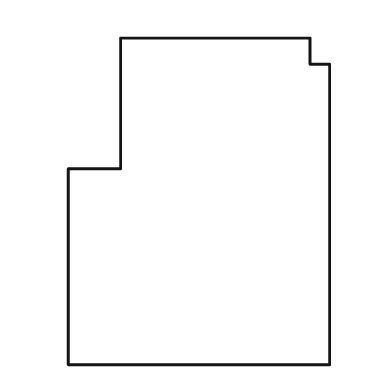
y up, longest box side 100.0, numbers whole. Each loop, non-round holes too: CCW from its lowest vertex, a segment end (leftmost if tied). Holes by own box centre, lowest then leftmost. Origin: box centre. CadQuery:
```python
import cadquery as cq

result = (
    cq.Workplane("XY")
    .moveTo(-40.0, -50.0)
    .lineTo(40.0, -50.0)
    .lineTo(40.0, 42.0)
    .lineTo(34.0, 42.0)
    .lineTo(34.0, 50.0)
    .lineTo(-24.0, 50.0)
    .lineTo(-24.0, 10.0)
    .lineTo(-40.0, 10.0)
    .close()
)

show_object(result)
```